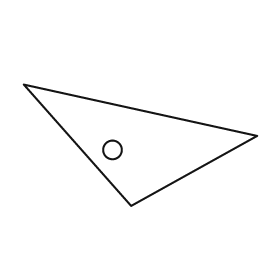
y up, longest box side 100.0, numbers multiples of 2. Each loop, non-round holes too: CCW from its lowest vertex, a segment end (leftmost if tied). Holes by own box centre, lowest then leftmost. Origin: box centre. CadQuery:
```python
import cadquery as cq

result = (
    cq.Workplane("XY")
    .moveTo(-4.0, -26.0)
    .lineTo(50.0, 4.0)
    .lineTo(-50.0, 26.0)
    .close()
    .moveTo(-12.0, -2.0)
    .circle(4.0)
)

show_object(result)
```